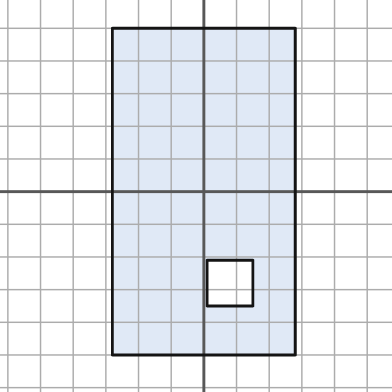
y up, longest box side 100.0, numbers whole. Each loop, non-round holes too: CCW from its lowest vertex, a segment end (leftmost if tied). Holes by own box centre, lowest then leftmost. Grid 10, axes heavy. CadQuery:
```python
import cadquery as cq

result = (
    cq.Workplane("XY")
    .moveTo(-28.0, -50.0)
    .lineTo(28.0, -50.0)
    .lineTo(28.0, 50.0)
    .lineTo(-28.0, 50.0)
    .close()
    .moveTo(1.0, -35.0)
    .lineTo(15.0, -35.0)
    .lineTo(15.0, -21.0)
    .lineTo(1.0, -21.0)
    .close()
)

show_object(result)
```